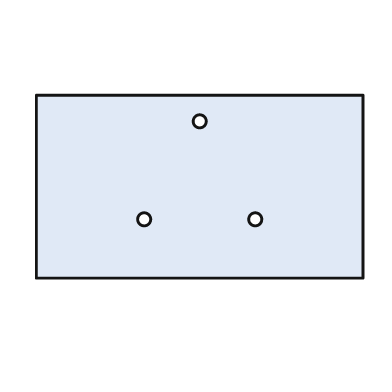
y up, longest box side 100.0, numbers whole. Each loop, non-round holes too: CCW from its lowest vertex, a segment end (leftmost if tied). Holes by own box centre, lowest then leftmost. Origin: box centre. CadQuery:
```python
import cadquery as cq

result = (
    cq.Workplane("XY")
    .moveTo(-50.0, -28.0)
    .lineTo(50.0, -28.0)
    .lineTo(50.0, 28.0)
    .lineTo(-50.0, 28.0)
    .close()
    .moveTo(-17.0, -10.0)
    .circle(2.0)
    .moveTo(17.0, -10.0)
    .circle(2.0)
    .moveTo(0.0, 20.0)
    .circle(2.0)
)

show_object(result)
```